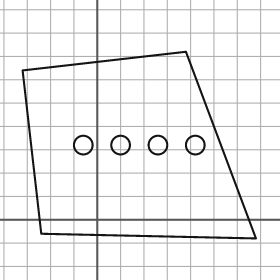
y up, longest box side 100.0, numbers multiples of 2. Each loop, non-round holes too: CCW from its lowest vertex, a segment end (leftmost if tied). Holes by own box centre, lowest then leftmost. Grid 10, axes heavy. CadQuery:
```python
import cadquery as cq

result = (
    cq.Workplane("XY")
    .moveTo(68.0, -8.0)
    .lineTo(38.0, 72.0)
    .lineTo(-32.0, 64.0)
    .lineTo(-24.0, -6.0)
    .close()
    .moveTo(-6.0, 32.0)
    .circle(4.0)
    .moveTo(10.0, 32.0)
    .circle(4.0)
    .moveTo(26.0, 32.0)
    .circle(4.0)
    .moveTo(42.0, 32.0)
    .circle(4.0)
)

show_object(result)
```